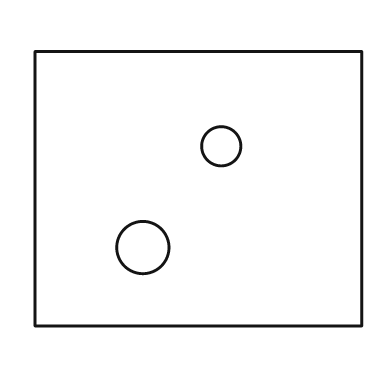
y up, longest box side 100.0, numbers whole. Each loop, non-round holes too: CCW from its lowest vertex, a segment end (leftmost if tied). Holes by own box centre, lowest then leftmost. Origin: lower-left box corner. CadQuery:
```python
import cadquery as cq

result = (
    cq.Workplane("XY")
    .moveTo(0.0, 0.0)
    .lineTo(100.0, 0.0)
    .lineTo(100.0, 84.0)
    .lineTo(0.0, 84.0)
    .close()
    .moveTo(33.0, 24.0)
    .circle(8.0)
    .moveTo(57.0, 55.0)
    .circle(6.0)
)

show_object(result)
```